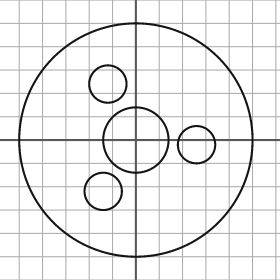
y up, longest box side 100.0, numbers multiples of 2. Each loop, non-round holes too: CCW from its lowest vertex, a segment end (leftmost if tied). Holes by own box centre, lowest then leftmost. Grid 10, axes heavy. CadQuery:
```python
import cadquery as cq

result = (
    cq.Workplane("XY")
    .moveTo(0.0, 0.0)
    .circle(50.0)
    .moveTo(-14.0, -22.0)
    .circle(8.0)
    .moveTo(26.0, -2.0)
    .circle(8.0)
    .moveTo(0.0, 0.0)
    .circle(14.0)
    .moveTo(-12.0, 24.0)
    .circle(8.0)
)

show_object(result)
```